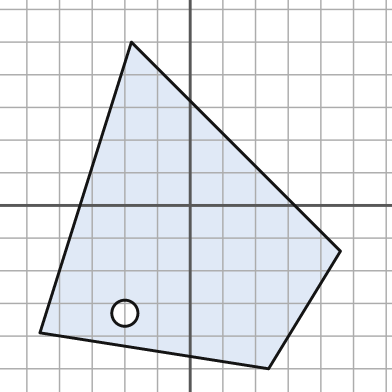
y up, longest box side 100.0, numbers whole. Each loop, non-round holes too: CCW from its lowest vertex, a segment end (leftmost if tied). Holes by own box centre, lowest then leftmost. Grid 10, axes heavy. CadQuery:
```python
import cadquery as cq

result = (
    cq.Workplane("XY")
    .moveTo(24.0, -50.0)
    .lineTo(46.0, -14.0)
    .lineTo(-18.0, 50.0)
    .lineTo(-46.0, -39.0)
    .close()
    .moveTo(-20.0, -33.0)
    .circle(4.0)
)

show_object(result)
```